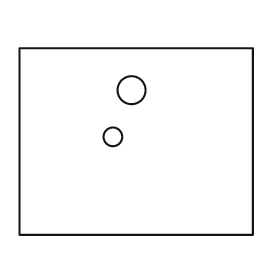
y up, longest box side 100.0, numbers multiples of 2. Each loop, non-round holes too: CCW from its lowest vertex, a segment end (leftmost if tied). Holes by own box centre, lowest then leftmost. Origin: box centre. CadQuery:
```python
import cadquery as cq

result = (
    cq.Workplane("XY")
    .moveTo(-50.0, -40.0)
    .lineTo(50.0, -40.0)
    .lineTo(50.0, 40.0)
    .lineTo(-50.0, 40.0)
    .close()
    .moveTo(-10.0, 2.0)
    .circle(4.0)
    .moveTo(-2.0, 22.0)
    .circle(6.0)
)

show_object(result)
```